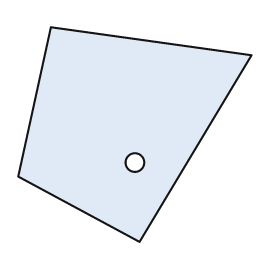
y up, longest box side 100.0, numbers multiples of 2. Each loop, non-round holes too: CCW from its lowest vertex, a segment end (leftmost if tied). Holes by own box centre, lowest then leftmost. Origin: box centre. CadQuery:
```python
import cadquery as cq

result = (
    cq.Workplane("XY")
    .moveTo(2.0, -46.0)
    .lineTo(50.0, 34.0)
    .lineTo(-36.0, 46.0)
    .lineTo(-50.0, -18.0)
    .close()
    .moveTo(0.0, -12.0)
    .circle(4.0)
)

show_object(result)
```